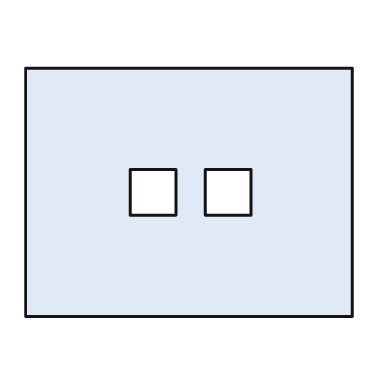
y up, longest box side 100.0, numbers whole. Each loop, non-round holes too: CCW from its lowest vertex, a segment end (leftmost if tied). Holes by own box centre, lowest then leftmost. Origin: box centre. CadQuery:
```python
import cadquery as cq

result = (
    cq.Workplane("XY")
    .moveTo(-50.0, -38.0)
    .lineTo(50.0, -38.0)
    .lineTo(50.0, 38.0)
    .lineTo(-50.0, 38.0)
    .close()
    .moveTo(-18.0, -7.0)
    .lineTo(-4.0, -7.0)
    .lineTo(-4.0, 7.0)
    .lineTo(-18.0, 7.0)
    .close()
    .moveTo(5.0, -7.0)
    .lineTo(19.0, -7.0)
    .lineTo(19.0, 7.0)
    .lineTo(5.0, 7.0)
    .close()
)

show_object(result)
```